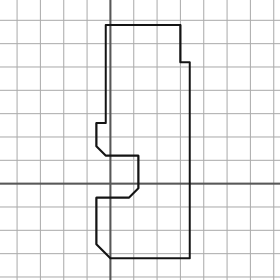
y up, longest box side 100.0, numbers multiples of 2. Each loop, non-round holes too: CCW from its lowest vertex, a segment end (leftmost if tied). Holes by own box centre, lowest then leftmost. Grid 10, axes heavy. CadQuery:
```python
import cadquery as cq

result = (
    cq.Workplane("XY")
    .moveTo(0.0, -32.0)
    .lineTo(34.0, -32.0)
    .lineTo(34.0, 52.0)
    .lineTo(30.0, 52.0)
    .lineTo(30.0, 68.0)
    .lineTo(-2.0, 68.0)
    .lineTo(-2.0, 26.0)
    .lineTo(-6.0, 26.0)
    .lineTo(-6.0, 16.0)
    .lineTo(-2.0, 12.0)
    .lineTo(12.0, 12.0)
    .lineTo(12.0, -2.0)
    .lineTo(8.0, -6.0)
    .lineTo(-6.0, -6.0)
    .lineTo(-6.0, -26.0)
    .close()
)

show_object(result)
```